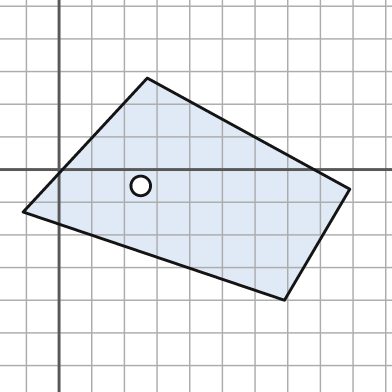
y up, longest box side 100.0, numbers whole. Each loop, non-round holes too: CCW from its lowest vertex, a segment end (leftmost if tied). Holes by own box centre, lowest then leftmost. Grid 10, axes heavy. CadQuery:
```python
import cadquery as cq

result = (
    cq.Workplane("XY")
    .moveTo(69.0, -40.0)
    .lineTo(89.0, -6.0)
    .lineTo(27.0, 28.0)
    .lineTo(-11.0, -13.0)
    .close()
    .moveTo(25.0, -5.0)
    .circle(3.0)
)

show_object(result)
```